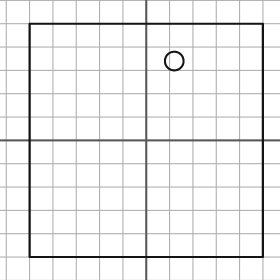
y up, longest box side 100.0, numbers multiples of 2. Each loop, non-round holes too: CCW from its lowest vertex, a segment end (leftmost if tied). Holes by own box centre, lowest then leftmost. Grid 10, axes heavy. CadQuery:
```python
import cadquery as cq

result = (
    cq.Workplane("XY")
    .moveTo(-50.0, -50.0)
    .lineTo(50.0, -50.0)
    .lineTo(50.0, 50.0)
    .lineTo(-50.0, 50.0)
    .close()
    .moveTo(12.0, 34.0)
    .circle(4.0)
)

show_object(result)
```